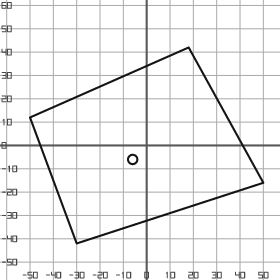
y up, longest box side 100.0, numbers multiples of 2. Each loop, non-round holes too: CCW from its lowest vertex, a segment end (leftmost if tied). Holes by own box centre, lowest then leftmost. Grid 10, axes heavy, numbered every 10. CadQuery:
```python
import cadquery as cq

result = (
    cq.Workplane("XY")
    .moveTo(-30.0, -42.0)
    .lineTo(50.0, -16.0)
    .lineTo(18.0, 42.0)
    .lineTo(-50.0, 12.0)
    .close()
    .moveTo(-6.0, -6.0)
    .circle(2.0)
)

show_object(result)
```